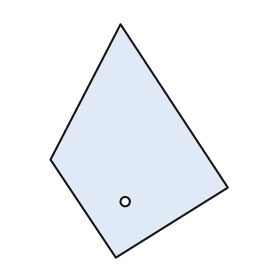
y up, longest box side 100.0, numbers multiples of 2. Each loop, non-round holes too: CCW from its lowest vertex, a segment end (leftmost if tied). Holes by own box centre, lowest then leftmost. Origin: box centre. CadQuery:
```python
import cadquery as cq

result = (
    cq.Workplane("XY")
    .moveTo(-10.0, -50.0)
    .lineTo(38.0, -20.0)
    .lineTo(-8.0, 50.0)
    .lineTo(-38.0, -8.0)
    .close()
    .moveTo(-6.0, -26.0)
    .circle(2.0)
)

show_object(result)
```